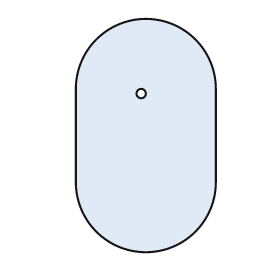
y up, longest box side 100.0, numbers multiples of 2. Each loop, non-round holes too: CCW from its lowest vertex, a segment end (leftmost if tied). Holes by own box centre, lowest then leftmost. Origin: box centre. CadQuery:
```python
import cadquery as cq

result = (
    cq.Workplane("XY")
    .moveTo(-30.0, -20.0)
    .threePointArc((0.0, -50.0), (30.0, -20.0))
    .lineTo(30.0, 20.0)
    .threePointArc((0.0, 50.0), (-30.0, 20.0))
    .close()
    .moveTo(-2.0, 18.0)
    .circle(2.0)
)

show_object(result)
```